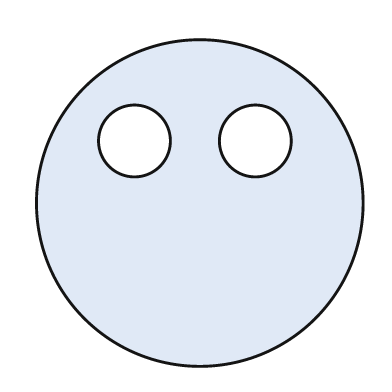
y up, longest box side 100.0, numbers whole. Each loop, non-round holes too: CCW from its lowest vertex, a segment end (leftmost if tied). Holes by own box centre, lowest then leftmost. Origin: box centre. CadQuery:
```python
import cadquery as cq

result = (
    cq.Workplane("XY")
    .moveTo(0.0, 0.0)
    .circle(50.0)
    .moveTo(-20.0, 19.0)
    .circle(11.0)
    .moveTo(17.0, 19.0)
    .circle(11.0)
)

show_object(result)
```